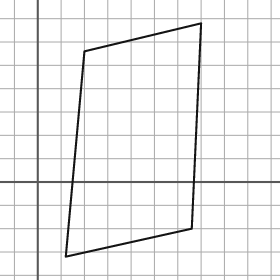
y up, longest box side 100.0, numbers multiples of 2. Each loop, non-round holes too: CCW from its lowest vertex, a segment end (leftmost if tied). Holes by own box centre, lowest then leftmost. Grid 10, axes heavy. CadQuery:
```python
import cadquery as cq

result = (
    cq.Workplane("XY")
    .moveTo(12.0, -32.0)
    .lineTo(66.0, -20.0)
    .lineTo(70.0, 68.0)
    .lineTo(20.0, 56.0)
    .close()
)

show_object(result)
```